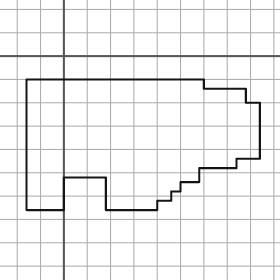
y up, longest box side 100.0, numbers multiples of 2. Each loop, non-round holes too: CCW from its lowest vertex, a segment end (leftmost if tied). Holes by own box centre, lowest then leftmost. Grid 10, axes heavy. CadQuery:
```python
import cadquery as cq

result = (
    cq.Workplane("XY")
    .moveTo(-16.0, -66.0)
    .lineTo(0.0, -66.0)
    .lineTo(0.0, -52.0)
    .lineTo(18.0, -52.0)
    .lineTo(18.0, -66.0)
    .lineTo(40.0, -66.0)
    .lineTo(40.0, -62.0)
    .lineTo(46.0, -62.0)
    .lineTo(46.0, -58.0)
    .lineTo(50.0, -58.0)
    .lineTo(50.0, -54.0)
    .lineTo(58.0, -54.0)
    .lineTo(58.0, -48.0)
    .lineTo(74.0, -48.0)
    .lineTo(74.0, -44.0)
    .lineTo(84.0, -44.0)
    .lineTo(84.0, -20.0)
    .lineTo(78.0, -20.0)
    .lineTo(78.0, -14.0)
    .lineTo(60.0, -14.0)
    .lineTo(60.0, -10.0)
    .lineTo(-16.0, -10.0)
    .close()
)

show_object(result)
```